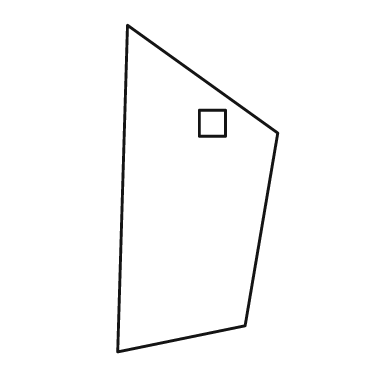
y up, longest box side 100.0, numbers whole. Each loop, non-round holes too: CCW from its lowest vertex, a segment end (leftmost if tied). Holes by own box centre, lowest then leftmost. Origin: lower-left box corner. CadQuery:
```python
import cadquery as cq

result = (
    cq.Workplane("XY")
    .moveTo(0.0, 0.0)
    .lineTo(39.0, 8.0)
    .lineTo(49.0, 67.0)
    .lineTo(3.0, 100.0)
    .close()
    .moveTo(25.0, 66.0)
    .lineTo(33.0, 66.0)
    .lineTo(33.0, 74.0)
    .lineTo(25.0, 74.0)
    .close()
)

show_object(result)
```